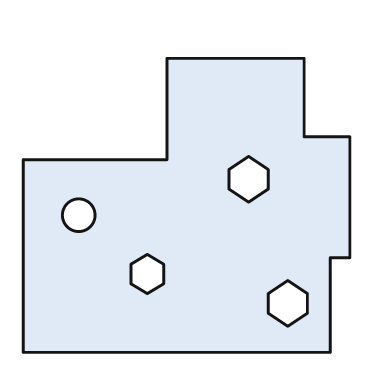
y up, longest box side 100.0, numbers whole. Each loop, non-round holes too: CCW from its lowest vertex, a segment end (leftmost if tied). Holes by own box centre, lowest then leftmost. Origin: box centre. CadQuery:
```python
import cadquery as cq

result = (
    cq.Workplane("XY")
    .moveTo(-50.0, -45.0)
    .lineTo(44.0, -45.0)
    .lineTo(44.0, -16.0)
    .lineTo(50.0, -16.0)
    .lineTo(50.0, 21.0)
    .lineTo(36.0, 21.0)
    .lineTo(36.0, 45.0)
    .lineTo(-6.0, 45.0)
    .lineTo(-6.0, 14.0)
    .lineTo(-50.0, 14.0)
    .close()
    .moveTo(31.0, -37.0)
    .lineTo(37.0, -33.0)
    .lineTo(37.0, -27.0)
    .lineTo(31.0, -23.0)
    .lineTo(25.0, -27.0)
    .lineTo(25.0, -33.0)
    .close()
    .moveTo(-12.0, -27.0)
    .lineTo(-7.0, -24.0)
    .lineTo(-7.0, -18.0)
    .lineTo(-12.0, -15.0)
    .lineTo(-17.0, -18.0)
    .lineTo(-17.0, -24.0)
    .close()
    .moveTo(-33.0, -3.0)
    .circle(5.0)
    .moveTo(19.0, 1.0)
    .lineTo(25.0, 5.0)
    .lineTo(25.0, 11.0)
    .lineTo(19.0, 15.0)
    .lineTo(13.0, 11.0)
    .lineTo(13.0, 5.0)
    .close()
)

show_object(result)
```